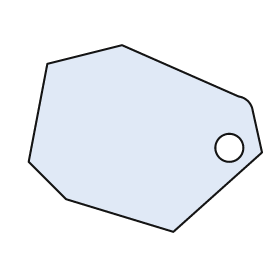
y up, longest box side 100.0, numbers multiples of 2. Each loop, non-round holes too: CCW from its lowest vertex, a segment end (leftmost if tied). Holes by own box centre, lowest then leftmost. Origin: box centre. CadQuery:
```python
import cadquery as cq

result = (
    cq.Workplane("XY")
    .moveTo(12.0, -40.0)
    .lineTo(50.0, -6.0)
    .lineTo(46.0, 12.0)
    .threePointArc((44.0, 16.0), (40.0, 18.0))
    .lineTo(-10.0, 40.0)
    .lineTo(-42.0, 32.0)
    .lineTo(-50.0, -10.0)
    .lineTo(-34.0, -26.0)
    .close()
    .moveTo(36.0, -4.0)
    .circle(6.0)
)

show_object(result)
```